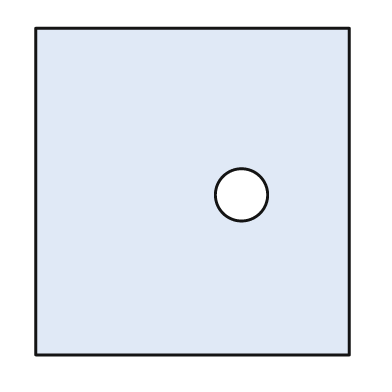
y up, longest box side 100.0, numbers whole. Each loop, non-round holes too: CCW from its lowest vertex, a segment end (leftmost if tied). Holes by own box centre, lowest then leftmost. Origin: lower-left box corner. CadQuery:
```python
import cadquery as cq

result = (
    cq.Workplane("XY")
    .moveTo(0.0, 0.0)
    .lineTo(96.0, 0.0)
    .lineTo(96.0, 100.0)
    .lineTo(0.0, 100.0)
    .close()
    .moveTo(63.0, 49.0)
    .circle(8.0)
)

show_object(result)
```